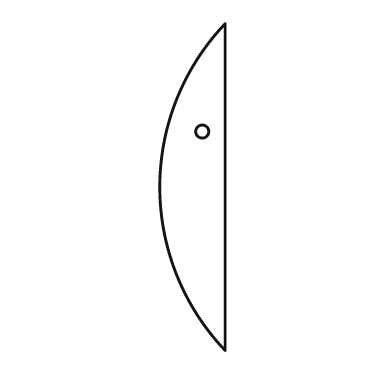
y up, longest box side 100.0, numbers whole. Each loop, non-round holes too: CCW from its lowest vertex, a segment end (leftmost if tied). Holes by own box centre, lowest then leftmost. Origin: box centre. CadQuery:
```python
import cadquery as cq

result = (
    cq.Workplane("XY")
    .moveTo(10.0, -50.0)
    .lineTo(10.0, 50.0)
    .threePointArc((-10.0, 0.0), (10.0, -50.0))
    .close()
    .moveTo(3.0, 17.0)
    .circle(2.0)
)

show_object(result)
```